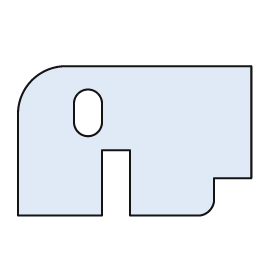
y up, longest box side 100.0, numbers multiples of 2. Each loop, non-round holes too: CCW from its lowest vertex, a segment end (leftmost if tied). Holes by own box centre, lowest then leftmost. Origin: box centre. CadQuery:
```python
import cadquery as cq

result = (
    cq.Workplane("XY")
    .moveTo(-50.0, -32.0)
    .lineTo(-14.0, -32.0)
    .lineTo(-14.0, -4.0)
    .lineTo(-2.0, -4.0)
    .lineTo(-2.0, -32.0)
    .lineTo(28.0, -32.0)
    .threePointArc((32.0, -30.0), (34.0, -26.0))
    .lineTo(34.0, -16.0)
    .lineTo(50.0, -16.0)
    .lineTo(50.0, 32.0)
    .lineTo(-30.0, 32.0)
    .threePointArc((-44.0, 26.0), (-50.0, 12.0))
    .close()
    .moveTo(-26.0, 8.0)
    .threePointArc((-20.0, 2.0), (-14.0, 8.0))
    .lineTo(-14.0, 16.0)
    .threePointArc((-20.0, 22.0), (-26.0, 16.0))
    .close()
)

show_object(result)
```